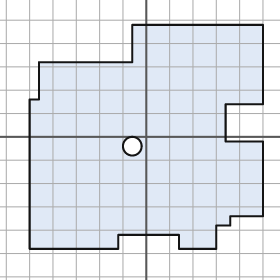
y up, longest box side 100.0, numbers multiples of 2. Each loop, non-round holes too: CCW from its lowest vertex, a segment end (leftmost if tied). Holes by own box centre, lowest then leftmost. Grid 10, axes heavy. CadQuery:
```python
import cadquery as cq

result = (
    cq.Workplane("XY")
    .moveTo(-50.0, -48.0)
    .lineTo(-12.0, -48.0)
    .lineTo(-12.0, -42.0)
    .lineTo(14.0, -42.0)
    .lineTo(14.0, -48.0)
    .lineTo(30.0, -48.0)
    .lineTo(30.0, -38.0)
    .lineTo(36.0, -38.0)
    .lineTo(36.0, -34.0)
    .lineTo(50.0, -34.0)
    .lineTo(50.0, -2.0)
    .lineTo(34.0, -2.0)
    .lineTo(34.0, 14.0)
    .lineTo(50.0, 14.0)
    .lineTo(50.0, 48.0)
    .lineTo(-6.0, 48.0)
    .lineTo(-6.0, 32.0)
    .lineTo(-46.0, 32.0)
    .lineTo(-46.0, 16.0)
    .lineTo(-50.0, 16.0)
    .close()
    .moveTo(-6.0, -4.0)
    .circle(4.0)
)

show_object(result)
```